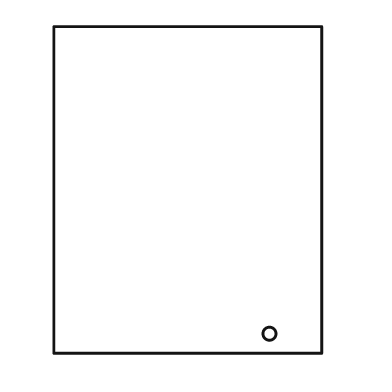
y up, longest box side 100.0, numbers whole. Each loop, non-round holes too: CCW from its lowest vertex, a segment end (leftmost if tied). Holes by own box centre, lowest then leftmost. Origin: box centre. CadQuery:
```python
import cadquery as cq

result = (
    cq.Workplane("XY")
    .moveTo(-41.0, -50.0)
    .lineTo(41.0, -50.0)
    .lineTo(41.0, 50.0)
    .lineTo(-41.0, 50.0)
    .close()
    .moveTo(25.0, -44.0)
    .circle(2.0)
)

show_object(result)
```